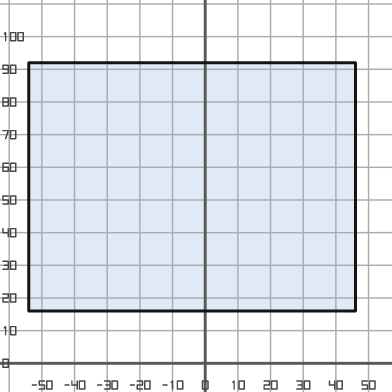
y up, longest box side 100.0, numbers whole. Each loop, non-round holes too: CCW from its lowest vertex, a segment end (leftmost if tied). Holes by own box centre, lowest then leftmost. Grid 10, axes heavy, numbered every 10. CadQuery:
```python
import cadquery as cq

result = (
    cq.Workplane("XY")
    .moveTo(-54.0, 16.0)
    .lineTo(46.0, 16.0)
    .lineTo(46.0, 92.0)
    .lineTo(-54.0, 92.0)
    .close()
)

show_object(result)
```